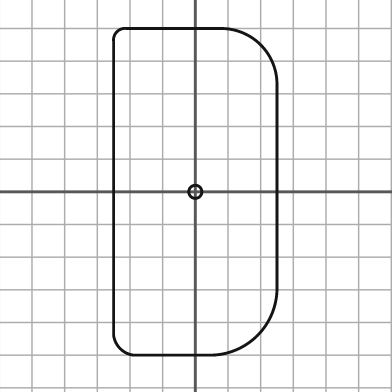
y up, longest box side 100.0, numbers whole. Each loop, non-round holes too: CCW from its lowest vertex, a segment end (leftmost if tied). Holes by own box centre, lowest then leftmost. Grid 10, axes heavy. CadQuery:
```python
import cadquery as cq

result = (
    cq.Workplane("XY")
    .moveTo(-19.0, -50.0)
    .lineTo(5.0, -50.0)
    .threePointArc((19.0, -44.0), (25.0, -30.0))
    .lineTo(25.0, 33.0)
    .threePointArc((20.0, 45.0), (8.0, 50.0))
    .lineTo(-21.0, 50.0)
    .threePointArc((-24.0, 49.0), (-25.0, 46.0))
    .lineTo(-25.0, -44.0)
    .threePointArc((-23.0, -48.0), (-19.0, -50.0))
    .close()
    .moveTo(0.0, 0.0)
    .circle(2.0)
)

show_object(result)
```